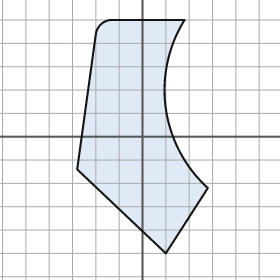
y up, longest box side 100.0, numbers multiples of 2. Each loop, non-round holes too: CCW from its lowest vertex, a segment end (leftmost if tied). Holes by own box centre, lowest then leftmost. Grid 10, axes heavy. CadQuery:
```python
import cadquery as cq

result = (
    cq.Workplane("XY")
    .moveTo(10.0, -50.0)
    .lineTo(28.0, -22.0)
    .threePointArc((10.0, 12.0), (18.0, 50.0))
    .lineTo(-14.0, 50.0)
    .threePointArc((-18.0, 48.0), (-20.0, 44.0))
    .lineTo(-28.0, -14.0)
    .close()
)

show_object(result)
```